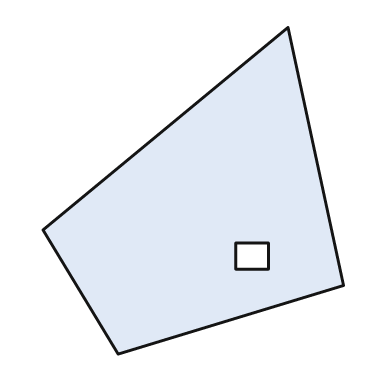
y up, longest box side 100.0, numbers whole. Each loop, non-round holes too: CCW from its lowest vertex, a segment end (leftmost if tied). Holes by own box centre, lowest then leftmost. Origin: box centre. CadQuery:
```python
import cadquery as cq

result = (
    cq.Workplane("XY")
    .moveTo(-23.0, -50.0)
    .lineTo(46.0, -29.0)
    .lineTo(29.0, 50.0)
    .lineTo(-46.0, -12.0)
    .close()
    .moveTo(13.0, -24.0)
    .lineTo(23.0, -24.0)
    .lineTo(23.0, -16.0)
    .lineTo(13.0, -16.0)
    .close()
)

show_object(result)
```